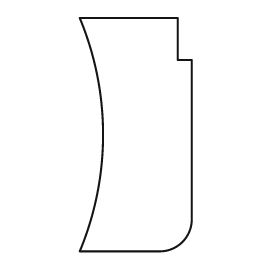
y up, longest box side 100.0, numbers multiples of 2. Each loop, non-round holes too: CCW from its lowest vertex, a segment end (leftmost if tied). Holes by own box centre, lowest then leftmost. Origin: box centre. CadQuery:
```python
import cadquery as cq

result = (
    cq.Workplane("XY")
    .moveTo(-24.0, -50.0)
    .lineTo(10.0, -50.0)
    .threePointArc((20.0, -46.0), (24.0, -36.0))
    .lineTo(24.0, 32.0)
    .lineTo(18.0, 32.0)
    .lineTo(18.0, 50.0)
    .lineTo(-24.0, 50.0)
    .threePointArc((-14.0, 0.0), (-24.0, -50.0))
    .close()
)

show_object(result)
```